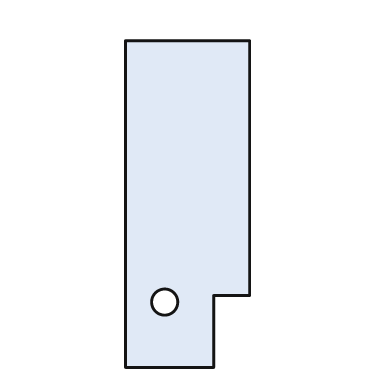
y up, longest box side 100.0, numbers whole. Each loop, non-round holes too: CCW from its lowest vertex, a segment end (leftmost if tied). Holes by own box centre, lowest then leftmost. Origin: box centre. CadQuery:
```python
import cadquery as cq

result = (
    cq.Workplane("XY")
    .moveTo(-19.0, -50.0)
    .lineTo(8.0, -50.0)
    .lineTo(8.0, -28.0)
    .lineTo(19.0, -28.0)
    .lineTo(19.0, 50.0)
    .lineTo(-19.0, 50.0)
    .close()
    .moveTo(-7.0, -30.0)
    .circle(4.0)
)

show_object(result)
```